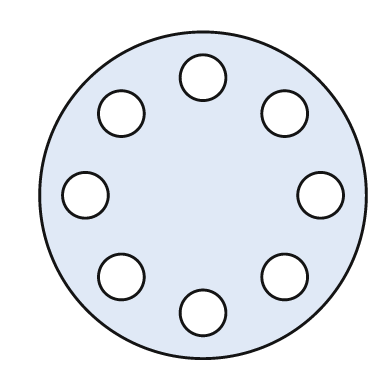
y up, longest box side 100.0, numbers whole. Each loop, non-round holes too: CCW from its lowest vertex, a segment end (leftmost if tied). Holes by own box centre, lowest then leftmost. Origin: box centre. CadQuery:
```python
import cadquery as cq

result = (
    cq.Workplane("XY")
    .moveTo(0.0, 0.0)
    .circle(50.0)
    .moveTo(0.0, -36.0)
    .circle(7.0)
    .moveTo(-25.0, -25.0)
    .circle(7.0)
    .moveTo(25.0, -25.0)
    .circle(7.0)
    .moveTo(-36.0, 0.0)
    .circle(7.0)
    .moveTo(36.0, 0.0)
    .circle(7.0)
    .moveTo(-25.0, 25.0)
    .circle(7.0)
    .moveTo(25.0, 25.0)
    .circle(7.0)
    .moveTo(0.0, 36.0)
    .circle(7.0)
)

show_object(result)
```